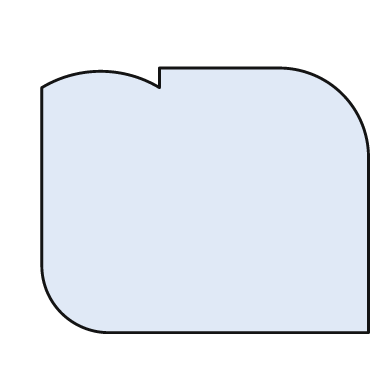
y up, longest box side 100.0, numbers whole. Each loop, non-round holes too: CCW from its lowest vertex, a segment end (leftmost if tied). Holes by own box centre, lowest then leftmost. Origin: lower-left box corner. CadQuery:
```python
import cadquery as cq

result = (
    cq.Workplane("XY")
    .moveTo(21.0, 0.0)
    .lineTo(100.0, 0.0)
    .lineTo(100.0, 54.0)
    .threePointArc((92.0, 73.0), (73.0, 81.0))
    .lineTo(36.0, 81.0)
    .lineTo(36.0, 75.0)
    .threePointArc((18.0, 80.0), (0.0, 75.0))
    .lineTo(0.0, 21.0)
    .threePointArc((6.0, 6.0), (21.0, 0.0))
    .close()
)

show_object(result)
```